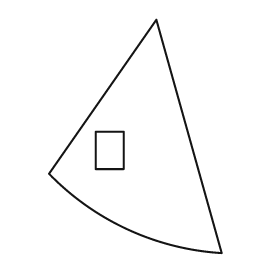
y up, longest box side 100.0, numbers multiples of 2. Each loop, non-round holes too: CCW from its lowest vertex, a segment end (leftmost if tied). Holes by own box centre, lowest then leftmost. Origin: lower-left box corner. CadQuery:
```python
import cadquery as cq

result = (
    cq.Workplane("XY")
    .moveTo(74.0, 0.0)
    .lineTo(46.0, 100.0)
    .lineTo(0.0, 34.0)
    .threePointArc((34.0, 10.0), (74.0, 0.0))
    .close()
    .moveTo(20.0, 36.0)
    .lineTo(32.0, 36.0)
    .lineTo(32.0, 52.0)
    .lineTo(20.0, 52.0)
    .close()
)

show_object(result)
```